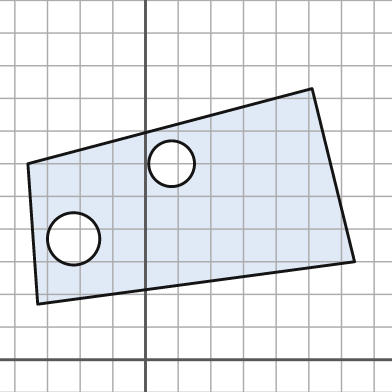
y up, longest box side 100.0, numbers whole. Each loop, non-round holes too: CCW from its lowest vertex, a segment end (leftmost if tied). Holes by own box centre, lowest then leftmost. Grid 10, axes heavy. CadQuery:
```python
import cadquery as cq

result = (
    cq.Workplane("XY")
    .moveTo(-33.0, 17.0)
    .lineTo(64.0, 30.0)
    .lineTo(51.0, 83.0)
    .lineTo(-36.0, 60.0)
    .close()
    .moveTo(-22.0, 37.0)
    .circle(8.0)
    .moveTo(8.0, 60.0)
    .circle(7.0)
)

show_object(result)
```